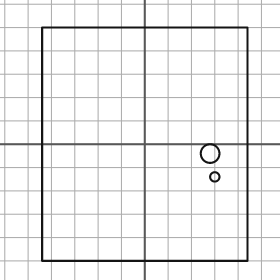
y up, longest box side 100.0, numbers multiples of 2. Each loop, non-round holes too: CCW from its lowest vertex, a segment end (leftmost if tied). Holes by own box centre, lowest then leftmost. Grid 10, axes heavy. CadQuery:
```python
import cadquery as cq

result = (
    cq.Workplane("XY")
    .moveTo(-44.0, -50.0)
    .lineTo(44.0, -50.0)
    .lineTo(44.0, 50.0)
    .lineTo(-44.0, 50.0)
    .close()
    .moveTo(30.0, -14.0)
    .circle(2.0)
    .moveTo(28.0, -4.0)
    .circle(4.0)
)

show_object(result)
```